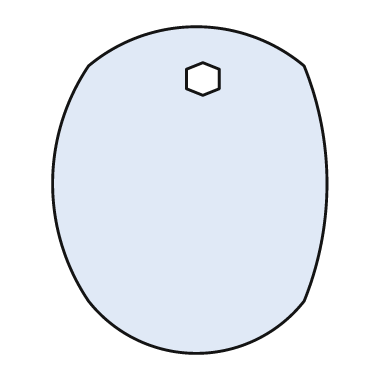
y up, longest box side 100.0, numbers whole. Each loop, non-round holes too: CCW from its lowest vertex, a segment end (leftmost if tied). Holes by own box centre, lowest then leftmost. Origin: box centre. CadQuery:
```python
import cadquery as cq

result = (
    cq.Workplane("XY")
    .moveTo(-31.0, -34.0)
    .threePointArc((2.0, -50.0), (35.0, -34.0))
    .threePointArc((42.0, 2.0), (35.0, 38.0))
    .threePointArc((2.0, 50.0), (-31.0, 38.0))
    .threePointArc((-42.0, 2.0), (-31.0, -34.0))
    .close()
    .moveTo(4.0, 29.0)
    .lineTo(9.0, 31.0)
    .lineTo(9.0, 37.0)
    .lineTo(4.0, 39.0)
    .lineTo(-1.0, 37.0)
    .lineTo(-1.0, 31.0)
    .close()
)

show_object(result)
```